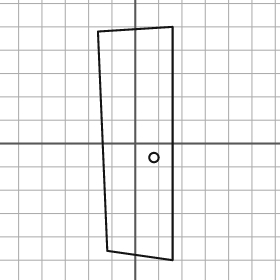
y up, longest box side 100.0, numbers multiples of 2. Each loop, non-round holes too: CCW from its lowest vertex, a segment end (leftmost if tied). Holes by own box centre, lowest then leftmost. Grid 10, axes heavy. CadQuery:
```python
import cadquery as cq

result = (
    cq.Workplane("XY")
    .moveTo(16.0, -50.0)
    .lineTo(16.0, 50.0)
    .lineTo(-16.0, 48.0)
    .lineTo(-12.0, -46.0)
    .close()
    .moveTo(8.0, -6.0)
    .circle(2.0)
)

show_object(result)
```